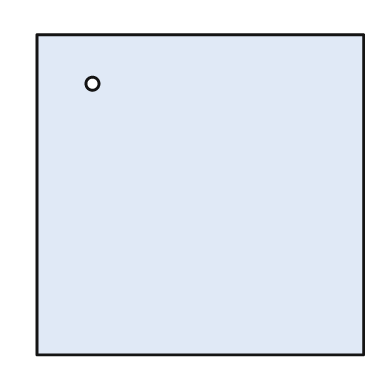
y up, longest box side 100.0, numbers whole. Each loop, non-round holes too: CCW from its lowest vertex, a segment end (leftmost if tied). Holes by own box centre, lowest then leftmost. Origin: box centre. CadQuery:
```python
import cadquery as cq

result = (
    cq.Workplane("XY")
    .moveTo(-50.0, -49.0)
    .lineTo(50.0, -49.0)
    .lineTo(50.0, 49.0)
    .lineTo(-50.0, 49.0)
    .close()
    .moveTo(-33.0, 34.0)
    .circle(2.0)
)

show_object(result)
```